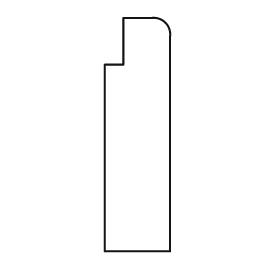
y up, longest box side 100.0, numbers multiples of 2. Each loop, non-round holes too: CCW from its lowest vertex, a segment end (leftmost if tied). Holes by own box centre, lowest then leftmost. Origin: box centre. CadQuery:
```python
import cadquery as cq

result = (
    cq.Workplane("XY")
    .moveTo(-14.0, -50.0)
    .lineTo(14.0, -50.0)
    .lineTo(14.0, 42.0)
    .threePointArc((12.0, 48.0), (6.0, 50.0))
    .lineTo(-6.0, 50.0)
    .lineTo(-6.0, 30.0)
    .lineTo(-14.0, 30.0)
    .close()
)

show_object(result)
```